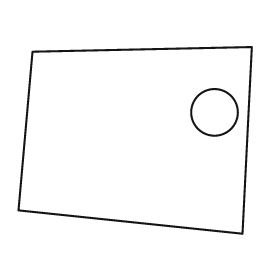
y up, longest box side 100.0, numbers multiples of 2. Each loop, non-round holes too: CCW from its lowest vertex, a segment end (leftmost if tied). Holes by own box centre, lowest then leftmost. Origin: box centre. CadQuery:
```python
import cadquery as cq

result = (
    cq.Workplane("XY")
    .moveTo(46.0, -40.0)
    .lineTo(50.0, 40.0)
    .lineTo(-44.0, 38.0)
    .lineTo(-50.0, -30.0)
    .close()
    .moveTo(34.0, 12.0)
    .circle(10.0)
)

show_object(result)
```